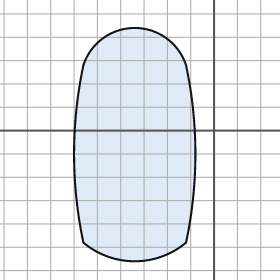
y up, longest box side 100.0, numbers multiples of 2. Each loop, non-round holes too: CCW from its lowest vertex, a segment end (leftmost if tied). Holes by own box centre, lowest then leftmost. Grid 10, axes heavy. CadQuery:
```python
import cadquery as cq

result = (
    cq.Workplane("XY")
    .moveTo(-56.0, -48.0)
    .threePointArc((-34.0, -56.0), (-12.0, -48.0))
    .threePointArc((-8.0, -10.0), (-12.0, 28.0))
    .threePointArc((-34.0, 44.0), (-56.0, 28.0))
    .threePointArc((-60.0, -10.0), (-56.0, -48.0))
    .close()
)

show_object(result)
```